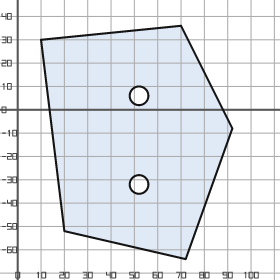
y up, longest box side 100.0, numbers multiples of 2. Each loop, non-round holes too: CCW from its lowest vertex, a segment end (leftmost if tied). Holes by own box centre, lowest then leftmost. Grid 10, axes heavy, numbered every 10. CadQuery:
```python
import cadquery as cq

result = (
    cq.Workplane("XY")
    .moveTo(72.0, -64.0)
    .lineTo(92.0, -8.0)
    .lineTo(70.0, 36.0)
    .lineTo(10.0, 30.0)
    .lineTo(20.0, -52.0)
    .close()
    .moveTo(52.0, -32.0)
    .circle(4.0)
    .moveTo(52.0, 6.0)
    .circle(4.0)
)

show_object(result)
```